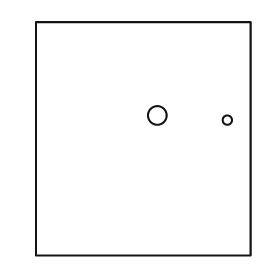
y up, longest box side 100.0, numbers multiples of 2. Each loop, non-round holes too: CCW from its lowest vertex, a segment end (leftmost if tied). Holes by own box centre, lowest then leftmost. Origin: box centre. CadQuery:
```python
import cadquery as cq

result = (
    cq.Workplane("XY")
    .moveTo(-46.0, -50.0)
    .lineTo(46.0, -50.0)
    .lineTo(46.0, 50.0)
    .lineTo(-46.0, 50.0)
    .close()
    .moveTo(36.0, 8.0)
    .circle(2.0)
    .moveTo(6.0, 10.0)
    .circle(4.0)
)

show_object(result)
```